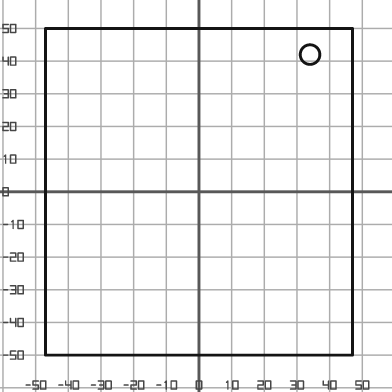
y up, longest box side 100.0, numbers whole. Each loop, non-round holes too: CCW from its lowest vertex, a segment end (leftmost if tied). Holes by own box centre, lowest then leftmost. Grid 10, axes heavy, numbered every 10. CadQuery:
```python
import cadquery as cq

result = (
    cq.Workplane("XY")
    .moveTo(-47.0, -50.0)
    .lineTo(47.0, -50.0)
    .lineTo(47.0, 50.0)
    .lineTo(-47.0, 50.0)
    .close()
    .moveTo(34.0, 42.0)
    .circle(3.0)
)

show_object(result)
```